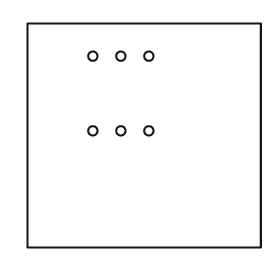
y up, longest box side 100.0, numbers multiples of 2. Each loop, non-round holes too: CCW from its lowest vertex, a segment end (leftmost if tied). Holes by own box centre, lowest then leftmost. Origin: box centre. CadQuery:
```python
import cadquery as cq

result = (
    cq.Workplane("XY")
    .moveTo(-50.0, -48.0)
    .lineTo(50.0, -48.0)
    .lineTo(50.0, 48.0)
    .lineTo(-50.0, 48.0)
    .close()
    .moveTo(-22.0, 2.0)
    .circle(2.0)
    .moveTo(-10.0, 2.0)
    .circle(2.0)
    .moveTo(2.0, 2.0)
    .circle(2.0)
    .moveTo(-22.0, 34.0)
    .circle(2.0)
    .moveTo(-10.0, 34.0)
    .circle(2.0)
    .moveTo(2.0, 34.0)
    .circle(2.0)
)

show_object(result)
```